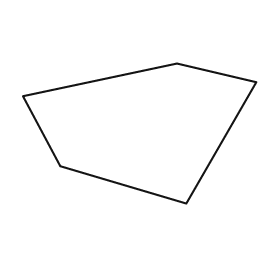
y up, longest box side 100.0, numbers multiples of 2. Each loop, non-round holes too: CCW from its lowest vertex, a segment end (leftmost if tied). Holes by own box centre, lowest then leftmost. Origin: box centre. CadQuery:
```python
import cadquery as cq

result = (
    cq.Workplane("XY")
    .moveTo(20.0, -30.0)
    .lineTo(50.0, 22.0)
    .lineTo(16.0, 30.0)
    .lineTo(-50.0, 16.0)
    .lineTo(-34.0, -14.0)
    .close()
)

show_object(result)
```